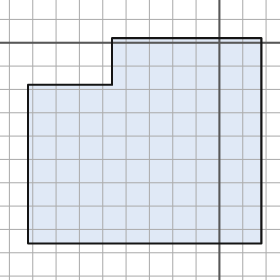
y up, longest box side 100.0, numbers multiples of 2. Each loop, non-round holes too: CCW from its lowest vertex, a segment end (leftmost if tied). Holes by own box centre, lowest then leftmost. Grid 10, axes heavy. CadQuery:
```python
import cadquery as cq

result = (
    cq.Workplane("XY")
    .moveTo(-82.0, -86.0)
    .lineTo(18.0, -86.0)
    .lineTo(18.0, 2.0)
    .lineTo(-46.0, 2.0)
    .lineTo(-46.0, -18.0)
    .lineTo(-82.0, -18.0)
    .close()
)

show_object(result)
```